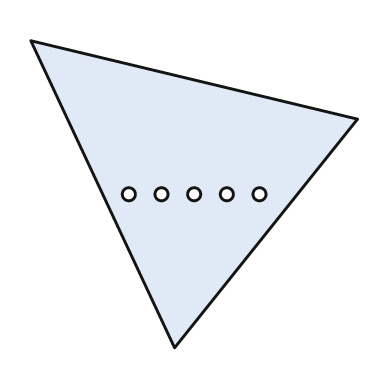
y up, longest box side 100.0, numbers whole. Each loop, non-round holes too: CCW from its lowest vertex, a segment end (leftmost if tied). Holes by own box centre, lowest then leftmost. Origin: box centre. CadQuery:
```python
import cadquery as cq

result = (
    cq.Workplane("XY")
    .moveTo(-6.0, -47.0)
    .lineTo(50.0, 23.0)
    .lineTo(-50.0, 47.0)
    .close()
    .moveTo(-20.0, 0.0)
    .circle(2.0)
    .moveTo(-10.0, 0.0)
    .circle(2.0)
    .moveTo(0.0, 0.0)
    .circle(2.0)
    .moveTo(10.0, 0.0)
    .circle(2.0)
    .moveTo(20.0, 0.0)
    .circle(2.0)
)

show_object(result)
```